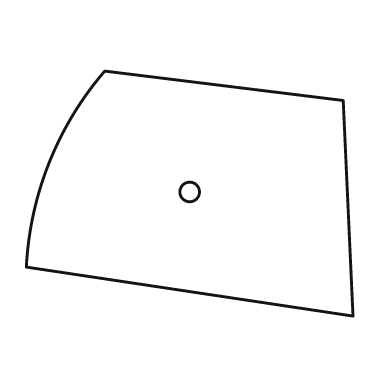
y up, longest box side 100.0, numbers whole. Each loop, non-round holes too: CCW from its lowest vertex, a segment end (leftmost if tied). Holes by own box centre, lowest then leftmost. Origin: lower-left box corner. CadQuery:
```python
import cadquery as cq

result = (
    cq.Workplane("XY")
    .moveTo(100.0, 0.0)
    .lineTo(97.0, 66.0)
    .lineTo(24.0, 75.0)
    .threePointArc((7.0, 47.0), (0.0, 15.0))
    .close()
    .moveTo(50.0, 38.0)
    .circle(3.0)
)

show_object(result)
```